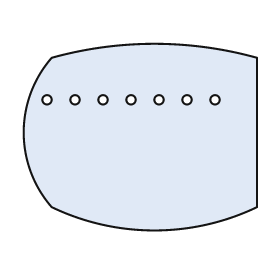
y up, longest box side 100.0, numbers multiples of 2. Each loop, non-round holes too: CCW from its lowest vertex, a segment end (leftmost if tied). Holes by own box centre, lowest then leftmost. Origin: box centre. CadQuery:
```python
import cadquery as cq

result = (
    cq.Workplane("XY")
    .moveTo(-38.0, -30.0)
    .threePointArc((6.0, -40.0), (50.0, -30.0))
    .lineTo(50.0, 34.0)
    .threePointArc((6.0, 40.0), (-38.0, 34.0))
    .threePointArc((-50.0, 2.0), (-38.0, -30.0))
    .close()
    .moveTo(-40.0, 16.0)
    .circle(2.0)
    .moveTo(-28.0, 16.0)
    .circle(2.0)
    .moveTo(-16.0, 16.0)
    .circle(2.0)
    .moveTo(-4.0, 16.0)
    .circle(2.0)
    .moveTo(8.0, 16.0)
    .circle(2.0)
    .moveTo(20.0, 16.0)
    .circle(2.0)
    .moveTo(32.0, 16.0)
    .circle(2.0)
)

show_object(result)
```